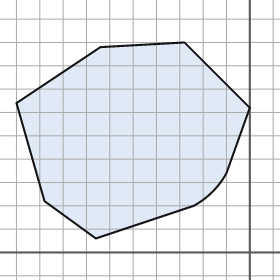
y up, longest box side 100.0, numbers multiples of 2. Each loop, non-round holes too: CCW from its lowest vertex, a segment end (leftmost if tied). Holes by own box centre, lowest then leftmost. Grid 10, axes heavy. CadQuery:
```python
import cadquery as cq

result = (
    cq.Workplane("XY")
    .moveTo(-66.0, 6.0)
    .lineTo(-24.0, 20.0)
    .threePointArc((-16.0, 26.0), (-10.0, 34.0))
    .lineTo(0.0, 62.0)
    .lineTo(-28.0, 90.0)
    .lineTo(-64.0, 88.0)
    .lineTo(-100.0, 64.0)
    .lineTo(-88.0, 22.0)
    .close()
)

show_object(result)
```